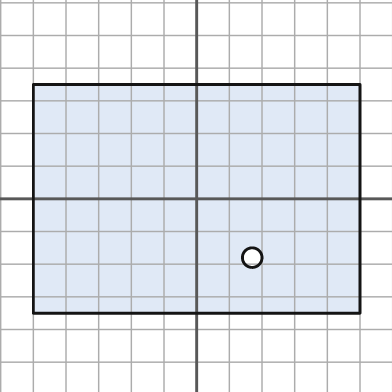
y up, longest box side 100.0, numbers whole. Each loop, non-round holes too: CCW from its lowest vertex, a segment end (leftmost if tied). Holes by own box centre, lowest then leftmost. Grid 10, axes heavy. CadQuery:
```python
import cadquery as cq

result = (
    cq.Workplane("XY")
    .moveTo(-50.0, -35.0)
    .lineTo(50.0, -35.0)
    .lineTo(50.0, 35.0)
    .lineTo(-50.0, 35.0)
    .close()
    .moveTo(17.0, -18.0)
    .circle(3.0)
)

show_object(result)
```